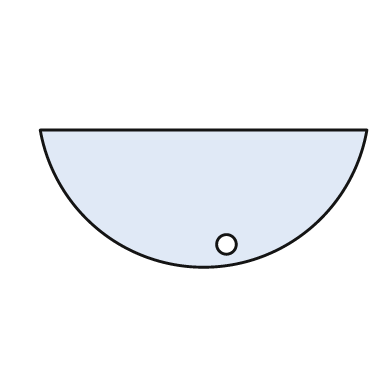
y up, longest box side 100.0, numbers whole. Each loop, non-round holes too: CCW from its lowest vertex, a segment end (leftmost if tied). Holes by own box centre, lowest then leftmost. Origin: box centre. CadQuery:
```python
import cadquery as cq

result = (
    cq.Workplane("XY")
    .moveTo(-50.0, 21.0)
    .threePointArc((0.0, -21.0), (50.0, 21.0))
    .close()
    .moveTo(7.0, -14.0)
    .circle(3.0)
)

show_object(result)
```